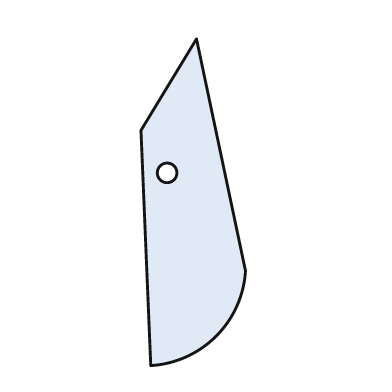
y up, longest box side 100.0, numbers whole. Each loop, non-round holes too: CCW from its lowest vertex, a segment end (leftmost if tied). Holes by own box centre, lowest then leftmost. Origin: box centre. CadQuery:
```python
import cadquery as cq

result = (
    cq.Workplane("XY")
    .moveTo(-13.0, -50.0)
    .threePointArc((7.0, -41.0), (16.0, -21.0))
    .lineTo(1.0, 50.0)
    .lineTo(-16.0, 22.0)
    .close()
    .moveTo(-8.0, 9.0)
    .circle(3.0)
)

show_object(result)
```